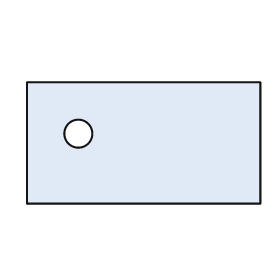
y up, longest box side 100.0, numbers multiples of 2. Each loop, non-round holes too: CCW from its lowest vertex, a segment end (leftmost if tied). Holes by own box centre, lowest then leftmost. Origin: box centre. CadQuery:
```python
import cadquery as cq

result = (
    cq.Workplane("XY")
    .moveTo(-50.0, -26.0)
    .lineTo(50.0, -26.0)
    .lineTo(50.0, 26.0)
    .lineTo(-50.0, 26.0)
    .close()
    .moveTo(-28.0, 4.0)
    .circle(6.0)
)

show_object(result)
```